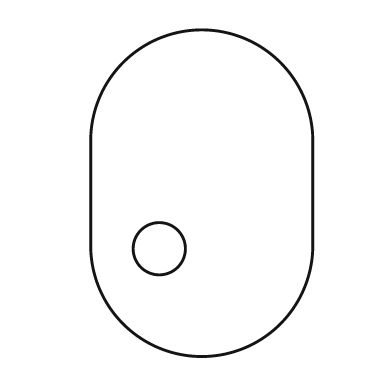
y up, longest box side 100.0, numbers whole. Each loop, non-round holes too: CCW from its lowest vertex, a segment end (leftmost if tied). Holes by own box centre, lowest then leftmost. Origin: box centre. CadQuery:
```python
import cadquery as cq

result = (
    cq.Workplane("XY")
    .moveTo(-34.0, -16.0)
    .threePointArc((0.0, -50.0), (34.0, -16.0))
    .lineTo(34.0, 16.0)
    .threePointArc((0.0, 50.0), (-34.0, 16.0))
    .close()
    .moveTo(-13.0, -17.0)
    .circle(8.0)
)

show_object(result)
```